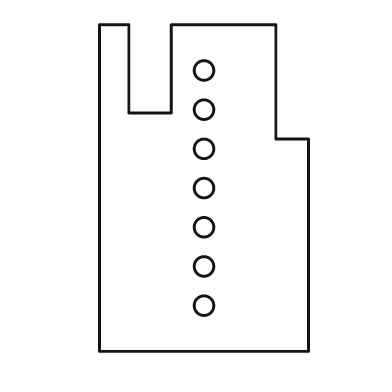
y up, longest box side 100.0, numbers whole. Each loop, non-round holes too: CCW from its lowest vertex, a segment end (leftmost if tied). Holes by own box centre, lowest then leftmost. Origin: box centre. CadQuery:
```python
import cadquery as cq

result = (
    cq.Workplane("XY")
    .moveTo(-32.0, -50.0)
    .lineTo(32.0, -50.0)
    .lineTo(32.0, 15.0)
    .lineTo(22.0, 15.0)
    .lineTo(22.0, 50.0)
    .lineTo(-10.0, 50.0)
    .lineTo(-10.0, 23.0)
    .lineTo(-23.0, 23.0)
    .lineTo(-23.0, 50.0)
    .lineTo(-32.0, 50.0)
    .close()
    .moveTo(0.0, -36.0)
    .circle(3.0)
    .moveTo(0.0, -24.0)
    .circle(3.0)
    .moveTo(0.0, -12.0)
    .circle(3.0)
    .moveTo(0.0, 0.0)
    .circle(3.0)
    .moveTo(0.0, 12.0)
    .circle(3.0)
    .moveTo(0.0, 24.0)
    .circle(3.0)
    .moveTo(0.0, 36.0)
    .circle(3.0)
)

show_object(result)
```